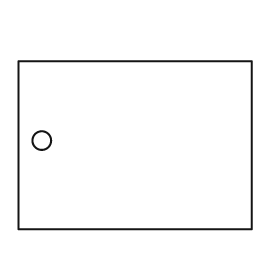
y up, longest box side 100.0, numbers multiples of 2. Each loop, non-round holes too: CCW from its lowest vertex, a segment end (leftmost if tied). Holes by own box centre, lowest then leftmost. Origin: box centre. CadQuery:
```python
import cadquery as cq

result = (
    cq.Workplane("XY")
    .moveTo(-50.0, -36.0)
    .lineTo(50.0, -36.0)
    .lineTo(50.0, 36.0)
    .lineTo(-50.0, 36.0)
    .close()
    .moveTo(-40.0, 2.0)
    .circle(4.0)
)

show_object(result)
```